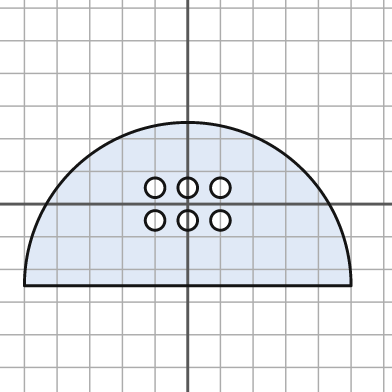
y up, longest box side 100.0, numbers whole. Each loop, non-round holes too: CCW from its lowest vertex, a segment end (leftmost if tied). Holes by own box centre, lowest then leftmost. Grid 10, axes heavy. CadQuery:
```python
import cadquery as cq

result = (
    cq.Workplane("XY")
    .moveTo(-50.0, -25.0)
    .lineTo(50.0, -25.0)
    .threePointArc((0.0, 25.0), (-50.0, -25.0))
    .close()
    .moveTo(-10.0, -5.0)
    .circle(3.0)
    .moveTo(0.0, -5.0)
    .circle(3.0)
    .moveTo(10.0, -5.0)
    .circle(3.0)
    .moveTo(-10.0, 5.0)
    .circle(3.0)
    .moveTo(0.0, 5.0)
    .circle(3.0)
    .moveTo(10.0, 5.0)
    .circle(3.0)
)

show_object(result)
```